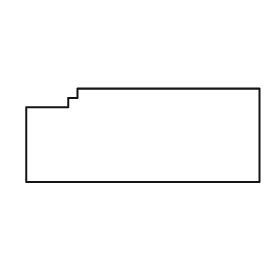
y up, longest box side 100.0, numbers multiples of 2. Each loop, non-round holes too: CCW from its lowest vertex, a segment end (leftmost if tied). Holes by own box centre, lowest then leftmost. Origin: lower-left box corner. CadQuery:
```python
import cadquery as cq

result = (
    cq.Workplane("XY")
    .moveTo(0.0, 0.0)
    .lineTo(100.0, 0.0)
    .lineTo(100.0, 40.0)
    .lineTo(22.0, 40.0)
    .lineTo(22.0, 36.0)
    .lineTo(18.0, 36.0)
    .lineTo(18.0, 32.0)
    .lineTo(0.0, 32.0)
    .close()
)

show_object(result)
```